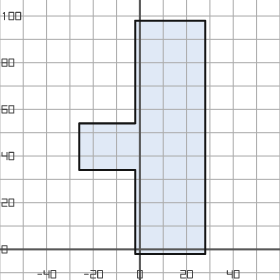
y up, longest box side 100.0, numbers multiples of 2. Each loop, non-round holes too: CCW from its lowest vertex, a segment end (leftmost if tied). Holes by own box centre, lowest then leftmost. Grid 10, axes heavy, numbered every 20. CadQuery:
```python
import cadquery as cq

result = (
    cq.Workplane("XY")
    .moveTo(-2.0, -2.0)
    .lineTo(28.0, -2.0)
    .lineTo(28.0, 98.0)
    .lineTo(-2.0, 98.0)
    .lineTo(-2.0, 54.0)
    .lineTo(-26.0, 54.0)
    .lineTo(-26.0, 34.0)
    .lineTo(-2.0, 34.0)
    .close()
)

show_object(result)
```